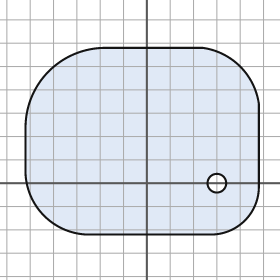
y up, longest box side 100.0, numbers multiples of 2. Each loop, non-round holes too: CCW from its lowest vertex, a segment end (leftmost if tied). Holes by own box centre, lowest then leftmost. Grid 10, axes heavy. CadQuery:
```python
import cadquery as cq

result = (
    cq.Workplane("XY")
    .moveTo(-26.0, -22.0)
    .lineTo(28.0, -22.0)
    .threePointArc((42.0, -16.0), (48.0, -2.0))
    .lineTo(48.0, 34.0)
    .threePointArc((40.0, 50.0), (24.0, 58.0))
    .lineTo(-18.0, 58.0)
    .threePointArc((-42.0, 48.0), (-52.0, 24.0))
    .lineTo(-52.0, 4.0)
    .threePointArc((-44.0, -14.0), (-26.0, -22.0))
    .close()
    .moveTo(30.0, 0.0)
    .circle(4.0)
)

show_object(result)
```